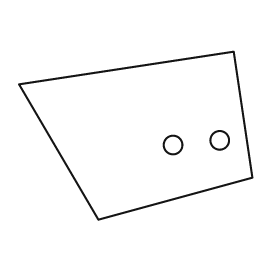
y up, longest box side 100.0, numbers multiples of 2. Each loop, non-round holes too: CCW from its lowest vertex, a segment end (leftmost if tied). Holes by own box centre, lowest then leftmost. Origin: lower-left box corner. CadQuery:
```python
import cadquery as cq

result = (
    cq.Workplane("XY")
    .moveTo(34.0, 0.0)
    .lineTo(100.0, 18.0)
    .lineTo(92.0, 72.0)
    .lineTo(0.0, 58.0)
    .close()
    .moveTo(66.0, 32.0)
    .circle(4.0)
    .moveTo(86.0, 34.0)
    .circle(4.0)
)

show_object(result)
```